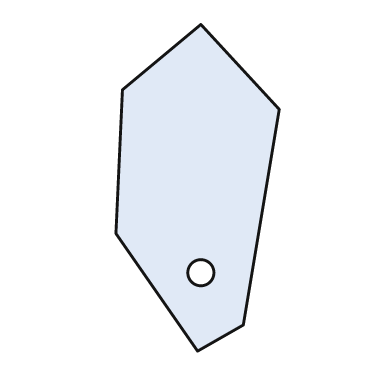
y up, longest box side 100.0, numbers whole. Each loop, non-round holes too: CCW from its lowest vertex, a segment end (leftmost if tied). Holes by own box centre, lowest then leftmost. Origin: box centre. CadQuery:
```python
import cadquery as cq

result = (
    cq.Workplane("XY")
    .moveTo(0.0, -50.0)
    .lineTo(14.0, -42.0)
    .lineTo(25.0, 24.0)
    .lineTo(1.0, 50.0)
    .lineTo(-23.0, 30.0)
    .lineTo(-25.0, -14.0)
    .close()
    .moveTo(1.0, -26.0)
    .circle(4.0)
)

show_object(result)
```